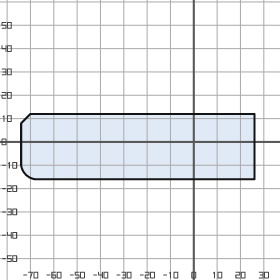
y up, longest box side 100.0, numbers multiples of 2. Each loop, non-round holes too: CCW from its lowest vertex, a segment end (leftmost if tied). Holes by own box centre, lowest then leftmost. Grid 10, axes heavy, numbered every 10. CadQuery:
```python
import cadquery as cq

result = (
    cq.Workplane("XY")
    .moveTo(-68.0, -16.0)
    .lineTo(26.0, -16.0)
    .lineTo(26.0, 12.0)
    .lineTo(-70.0, 12.0)
    .lineTo(-74.0, 8.0)
    .lineTo(-74.0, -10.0)
    .threePointArc((-72.0, -14.0), (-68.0, -16.0))
    .close()
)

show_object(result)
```